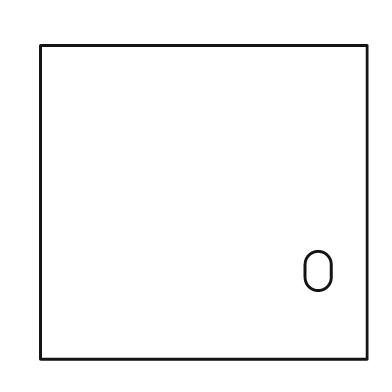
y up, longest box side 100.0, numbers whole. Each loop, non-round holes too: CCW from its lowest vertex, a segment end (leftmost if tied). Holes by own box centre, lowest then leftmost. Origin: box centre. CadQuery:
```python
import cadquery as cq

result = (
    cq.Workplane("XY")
    .moveTo(-50.0, -48.0)
    .lineTo(50.0, -48.0)
    .lineTo(50.0, 48.0)
    .lineTo(-50.0, 48.0)
    .close()
    .moveTo(31.0, -23.0)
    .threePointArc((35.0, -27.0), (39.0, -23.0))
    .lineTo(39.0, -19.0)
    .threePointArc((35.0, -15.0), (31.0, -19.0))
    .close()
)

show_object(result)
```